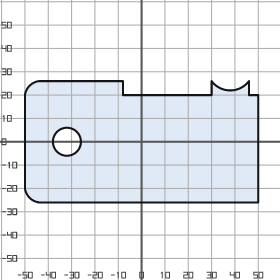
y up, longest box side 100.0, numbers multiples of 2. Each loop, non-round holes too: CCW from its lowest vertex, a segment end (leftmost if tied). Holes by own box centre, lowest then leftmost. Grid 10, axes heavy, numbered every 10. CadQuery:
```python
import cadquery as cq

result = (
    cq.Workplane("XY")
    .moveTo(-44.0, -26.0)
    .lineTo(50.0, -26.0)
    .lineTo(50.0, 20.0)
    .lineTo(46.0, 20.0)
    .lineTo(46.0, 26.0)
    .threePointArc((38.0, 22.0), (30.0, 26.0))
    .lineTo(30.0, 20.0)
    .lineTo(-8.0, 20.0)
    .lineTo(-8.0, 26.0)
    .lineTo(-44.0, 26.0)
    .threePointArc((-48.0, 24.0), (-50.0, 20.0))
    .lineTo(-50.0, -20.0)
    .threePointArc((-48.0, -24.0), (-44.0, -26.0))
    .close()
    .moveTo(-32.0, 0.0)
    .circle(6.0)
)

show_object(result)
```